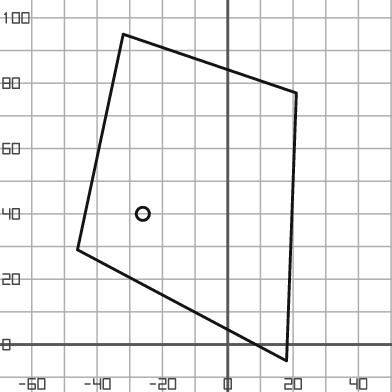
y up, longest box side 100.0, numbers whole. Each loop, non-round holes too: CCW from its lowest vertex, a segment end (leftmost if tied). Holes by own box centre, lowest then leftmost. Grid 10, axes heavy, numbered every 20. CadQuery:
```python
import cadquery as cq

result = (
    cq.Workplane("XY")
    .moveTo(18.0, -5.0)
    .lineTo(21.0, 77.0)
    .lineTo(-32.0, 95.0)
    .lineTo(-46.0, 29.0)
    .close()
    .moveTo(-26.0, 40.0)
    .circle(2.0)
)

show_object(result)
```